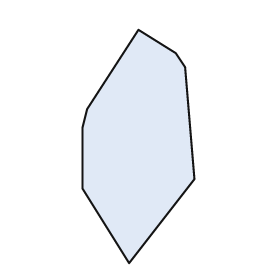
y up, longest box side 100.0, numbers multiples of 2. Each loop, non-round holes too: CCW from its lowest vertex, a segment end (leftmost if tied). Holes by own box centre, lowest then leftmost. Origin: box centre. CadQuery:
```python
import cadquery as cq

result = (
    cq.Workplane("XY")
    .moveTo(-4.0, -50.0)
    .lineTo(24.0, -14.0)
    .lineTo(20.0, 34.0)
    .lineTo(16.0, 40.0)
    .lineTo(0.0, 50.0)
    .lineTo(-22.0, 16.0)
    .lineTo(-24.0, 8.0)
    .lineTo(-24.0, -18.0)
    .close()
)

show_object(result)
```